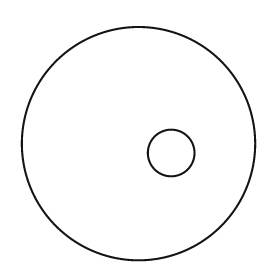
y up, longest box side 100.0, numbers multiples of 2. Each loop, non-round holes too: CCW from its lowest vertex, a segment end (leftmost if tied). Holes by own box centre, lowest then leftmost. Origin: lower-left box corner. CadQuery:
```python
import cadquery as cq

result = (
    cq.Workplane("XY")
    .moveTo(50.0, 50.0)
    .circle(50.0)
    .moveTo(64.0, 46.0)
    .circle(10.0)
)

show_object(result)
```